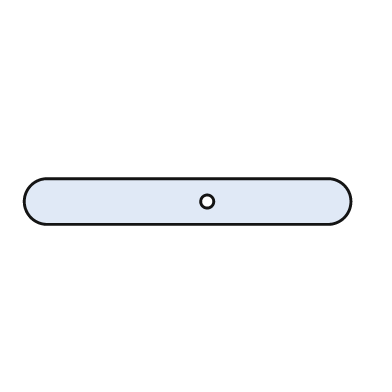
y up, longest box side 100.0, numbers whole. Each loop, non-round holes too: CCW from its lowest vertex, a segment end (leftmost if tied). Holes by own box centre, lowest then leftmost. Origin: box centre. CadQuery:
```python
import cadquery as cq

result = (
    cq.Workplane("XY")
    .moveTo(-43.0, -7.0)
    .lineTo(43.0, -7.0)
    .threePointArc((50.0, 0.0), (43.0, 7.0))
    .lineTo(-43.0, 7.0)
    .threePointArc((-50.0, 0.0), (-43.0, -7.0))
    .close()
    .moveTo(6.0, 0.0)
    .circle(2.0)
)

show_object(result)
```